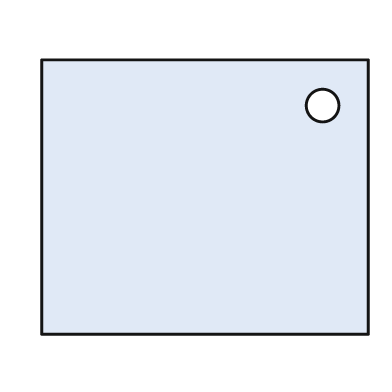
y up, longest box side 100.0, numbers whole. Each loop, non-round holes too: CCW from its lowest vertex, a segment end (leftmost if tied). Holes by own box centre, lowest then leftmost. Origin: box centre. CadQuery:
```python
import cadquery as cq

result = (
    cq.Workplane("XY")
    .moveTo(-50.0, -42.0)
    .lineTo(50.0, -42.0)
    .lineTo(50.0, 42.0)
    .lineTo(-50.0, 42.0)
    .close()
    .moveTo(36.0, 28.0)
    .circle(5.0)
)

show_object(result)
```